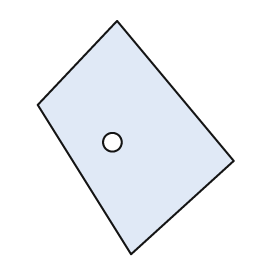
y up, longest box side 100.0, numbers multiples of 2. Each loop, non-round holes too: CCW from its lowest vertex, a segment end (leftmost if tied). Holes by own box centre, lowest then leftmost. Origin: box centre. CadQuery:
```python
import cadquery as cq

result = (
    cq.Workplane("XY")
    .moveTo(-2.0, -50.0)
    .lineTo(42.0, -10.0)
    .lineTo(-8.0, 50.0)
    .lineTo(-42.0, 14.0)
    .close()
    .moveTo(-10.0, -2.0)
    .circle(4.0)
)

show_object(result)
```